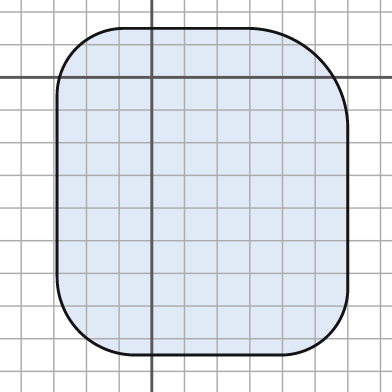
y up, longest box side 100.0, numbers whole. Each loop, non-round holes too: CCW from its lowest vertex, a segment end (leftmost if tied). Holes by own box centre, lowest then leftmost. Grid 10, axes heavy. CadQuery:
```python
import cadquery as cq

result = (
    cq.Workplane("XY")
    .moveTo(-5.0, -85.0)
    .lineTo(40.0, -85.0)
    .threePointArc((54.0, -79.0), (60.0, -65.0))
    .lineTo(60.0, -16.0)
    .threePointArc((51.0, 6.0), (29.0, 15.0))
    .lineTo(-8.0, 15.0)
    .threePointArc((-23.0, 9.0), (-29.0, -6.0))
    .lineTo(-29.0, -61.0)
    .threePointArc((-22.0, -78.0), (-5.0, -85.0))
    .close()
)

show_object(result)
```